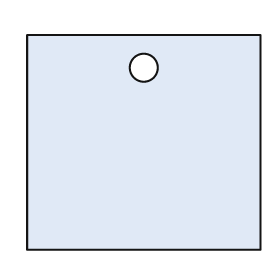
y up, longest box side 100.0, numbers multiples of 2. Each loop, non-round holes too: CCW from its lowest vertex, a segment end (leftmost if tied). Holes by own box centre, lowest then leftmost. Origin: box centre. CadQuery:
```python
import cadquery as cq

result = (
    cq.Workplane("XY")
    .moveTo(-50.0, -46.0)
    .lineTo(50.0, -46.0)
    .lineTo(50.0, 46.0)
    .lineTo(-50.0, 46.0)
    .close()
    .moveTo(0.0, 32.0)
    .circle(6.0)
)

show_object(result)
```